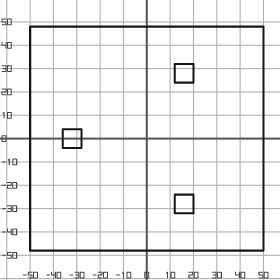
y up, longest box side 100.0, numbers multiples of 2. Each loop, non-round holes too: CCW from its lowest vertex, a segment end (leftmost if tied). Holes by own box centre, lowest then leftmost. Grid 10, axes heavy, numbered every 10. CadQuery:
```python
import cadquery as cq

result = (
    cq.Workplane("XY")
    .moveTo(-50.0, -48.0)
    .lineTo(50.0, -48.0)
    .lineTo(50.0, 48.0)
    .lineTo(-50.0, 48.0)
    .close()
    .moveTo(12.0, -32.0)
    .lineTo(20.0, -32.0)
    .lineTo(20.0, -24.0)
    .lineTo(12.0, -24.0)
    .close()
    .moveTo(-36.0, -4.0)
    .lineTo(-28.0, -4.0)
    .lineTo(-28.0, 4.0)
    .lineTo(-36.0, 4.0)
    .close()
    .moveTo(12.0, 24.0)
    .lineTo(20.0, 24.0)
    .lineTo(20.0, 32.0)
    .lineTo(12.0, 32.0)
    .close()
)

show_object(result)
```